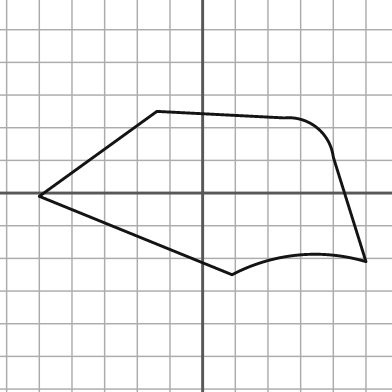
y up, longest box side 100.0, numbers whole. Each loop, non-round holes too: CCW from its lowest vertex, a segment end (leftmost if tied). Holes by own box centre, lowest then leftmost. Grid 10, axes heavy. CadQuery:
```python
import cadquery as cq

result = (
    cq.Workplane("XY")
    .moveTo(9.0, -25.0)
    .threePointArc((29.0, -19.0), (50.0, -21.0))
    .lineTo(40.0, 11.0)
    .threePointArc((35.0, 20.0), (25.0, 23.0))
    .lineTo(-14.0, 25.0)
    .lineTo(-50.0, -1.0)
    .close()
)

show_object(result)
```